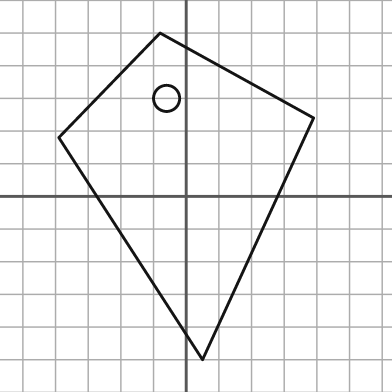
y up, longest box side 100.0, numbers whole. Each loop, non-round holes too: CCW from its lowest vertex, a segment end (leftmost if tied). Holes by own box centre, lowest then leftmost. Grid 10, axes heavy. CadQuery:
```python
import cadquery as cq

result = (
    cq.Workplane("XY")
    .moveTo(5.0, -50.0)
    .lineTo(39.0, 24.0)
    .lineTo(-8.0, 50.0)
    .lineTo(-39.0, 18.0)
    .close()
    .moveTo(-6.0, 30.0)
    .circle(4.0)
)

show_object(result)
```